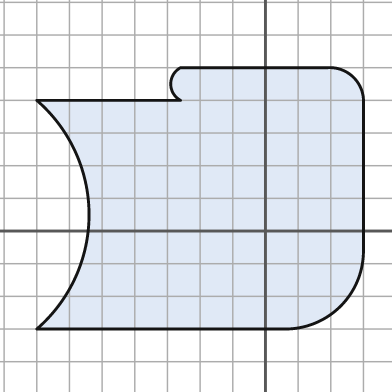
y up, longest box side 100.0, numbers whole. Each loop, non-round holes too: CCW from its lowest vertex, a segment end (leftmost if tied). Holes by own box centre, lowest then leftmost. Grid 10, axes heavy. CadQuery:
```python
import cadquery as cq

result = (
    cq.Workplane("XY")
    .moveTo(-70.0, -30.0)
    .lineTo(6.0, -30.0)
    .threePointArc((23.0, -23.0), (30.0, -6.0))
    .lineTo(30.0, 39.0)
    .threePointArc((27.0, 47.0), (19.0, 50.0))
    .lineTo(-26.0, 50.0)
    .threePointArc((-29.0, 45.0), (-26.0, 40.0))
    .lineTo(-70.0, 40.0)
    .threePointArc((-54.0, 5.0), (-70.0, -30.0))
    .close()
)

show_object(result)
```